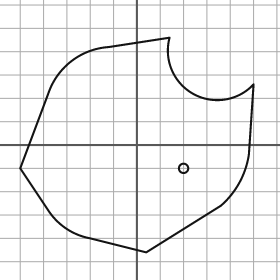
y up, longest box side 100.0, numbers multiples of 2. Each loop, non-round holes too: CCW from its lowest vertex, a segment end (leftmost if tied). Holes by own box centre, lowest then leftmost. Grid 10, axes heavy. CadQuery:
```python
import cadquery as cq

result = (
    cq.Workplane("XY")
    .moveTo(4.0, -46.0)
    .lineTo(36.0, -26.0)
    .threePointArc((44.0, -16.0), (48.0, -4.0))
    .lineTo(50.0, 26.0)
    .threePointArc((24.0, 22.0), (14.0, 46.0))
    .lineTo(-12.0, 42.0)
    .threePointArc((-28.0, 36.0), (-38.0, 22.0))
    .lineTo(-50.0, -10.0)
    .lineTo(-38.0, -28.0)
    .threePointArc((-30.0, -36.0), (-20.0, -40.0))
    .close()
    .moveTo(20.0, -10.0)
    .circle(2.0)
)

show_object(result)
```